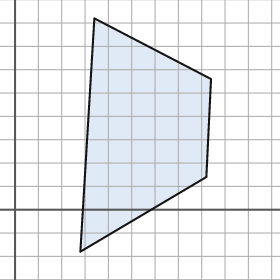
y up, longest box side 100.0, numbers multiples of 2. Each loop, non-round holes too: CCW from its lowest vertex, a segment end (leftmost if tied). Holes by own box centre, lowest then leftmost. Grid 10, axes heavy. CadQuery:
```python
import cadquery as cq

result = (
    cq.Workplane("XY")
    .moveTo(28.0, -18.0)
    .lineTo(82.0, 14.0)
    .lineTo(84.0, 56.0)
    .lineTo(34.0, 82.0)
    .close()
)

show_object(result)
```